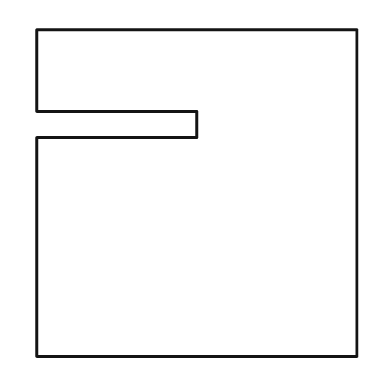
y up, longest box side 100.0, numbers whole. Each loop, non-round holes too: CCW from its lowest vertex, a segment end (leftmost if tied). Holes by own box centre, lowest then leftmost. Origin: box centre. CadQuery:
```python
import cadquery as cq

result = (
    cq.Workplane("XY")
    .moveTo(-49.0, -50.0)
    .lineTo(49.0, -50.0)
    .lineTo(49.0, 50.0)
    .lineTo(-49.0, 50.0)
    .lineTo(-49.0, 25.0)
    .lineTo(0.0, 25.0)
    .lineTo(0.0, 17.0)
    .lineTo(-49.0, 17.0)
    .close()
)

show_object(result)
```